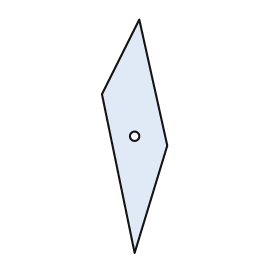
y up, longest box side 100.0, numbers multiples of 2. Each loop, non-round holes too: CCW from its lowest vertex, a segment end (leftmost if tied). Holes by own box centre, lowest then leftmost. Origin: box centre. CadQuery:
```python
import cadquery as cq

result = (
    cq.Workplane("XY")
    .moveTo(0.0, -50.0)
    .lineTo(14.0, -4.0)
    .lineTo(2.0, 50.0)
    .lineTo(-14.0, 18.0)
    .close()
    .moveTo(0.0, 0.0)
    .circle(2.0)
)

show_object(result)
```